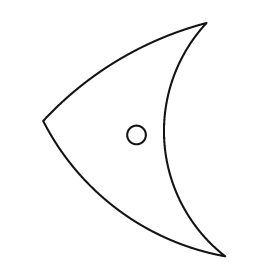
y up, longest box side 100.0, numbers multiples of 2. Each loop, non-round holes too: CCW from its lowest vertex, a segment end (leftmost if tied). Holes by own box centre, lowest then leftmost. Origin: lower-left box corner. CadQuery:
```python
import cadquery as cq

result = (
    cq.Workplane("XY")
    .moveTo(78.0, 0.0)
    .threePointArc((52.0, 48.0), (70.0, 100.0))
    .threePointArc((32.0, 84.0), (0.0, 58.0))
    .threePointArc((32.0, 20.0), (78.0, 0.0))
    .close()
    .moveTo(40.0, 52.0)
    .circle(4.0)
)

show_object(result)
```